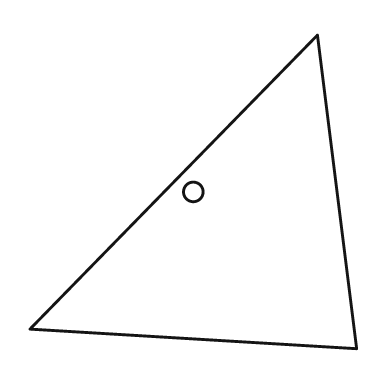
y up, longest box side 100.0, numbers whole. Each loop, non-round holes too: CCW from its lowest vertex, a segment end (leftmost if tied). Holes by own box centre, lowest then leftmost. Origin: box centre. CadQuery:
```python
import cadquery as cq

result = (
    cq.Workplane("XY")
    .moveTo(50.0, -48.0)
    .lineTo(38.0, 48.0)
    .lineTo(-50.0, -42.0)
    .close()
    .moveTo(0.0, 0.0)
    .circle(3.0)
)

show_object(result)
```